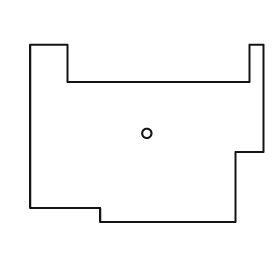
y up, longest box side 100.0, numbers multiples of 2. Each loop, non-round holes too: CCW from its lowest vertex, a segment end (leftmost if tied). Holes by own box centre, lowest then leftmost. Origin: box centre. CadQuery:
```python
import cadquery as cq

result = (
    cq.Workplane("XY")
    .moveTo(-20.0, -38.0)
    .lineTo(38.0, -38.0)
    .lineTo(38.0, -8.0)
    .lineTo(50.0, -8.0)
    .lineTo(50.0, 38.0)
    .lineTo(44.0, 38.0)
    .lineTo(44.0, 22.0)
    .lineTo(-34.0, 22.0)
    .lineTo(-34.0, 38.0)
    .lineTo(-50.0, 38.0)
    .lineTo(-50.0, -32.0)
    .lineTo(-20.0, -32.0)
    .close()
    .moveTo(0.0, 0.0)
    .circle(2.0)
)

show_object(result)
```